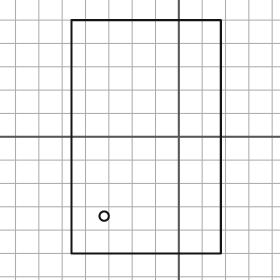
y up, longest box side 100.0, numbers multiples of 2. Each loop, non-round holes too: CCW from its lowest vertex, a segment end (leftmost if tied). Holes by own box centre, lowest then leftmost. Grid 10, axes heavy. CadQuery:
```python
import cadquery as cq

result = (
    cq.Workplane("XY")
    .moveTo(-46.0, -50.0)
    .lineTo(18.0, -50.0)
    .lineTo(18.0, 50.0)
    .lineTo(-46.0, 50.0)
    .close()
    .moveTo(-32.0, -34.0)
    .circle(2.0)
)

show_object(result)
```